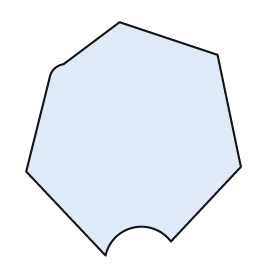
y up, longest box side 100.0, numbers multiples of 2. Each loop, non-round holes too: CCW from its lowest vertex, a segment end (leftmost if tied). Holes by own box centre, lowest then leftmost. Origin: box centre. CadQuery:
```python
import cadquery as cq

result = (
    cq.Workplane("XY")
    .moveTo(-12.0, -50.0)
    .threePointArc((0.0, -38.0), (16.0, -44.0))
    .lineTo(46.0, -12.0)
    .lineTo(36.0, 36.0)
    .lineTo(-6.0, 50.0)
    .lineTo(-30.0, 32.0)
    .threePointArc((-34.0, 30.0), (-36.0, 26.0))
    .lineTo(-46.0, -14.0)
    .close()
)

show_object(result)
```